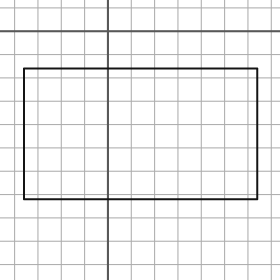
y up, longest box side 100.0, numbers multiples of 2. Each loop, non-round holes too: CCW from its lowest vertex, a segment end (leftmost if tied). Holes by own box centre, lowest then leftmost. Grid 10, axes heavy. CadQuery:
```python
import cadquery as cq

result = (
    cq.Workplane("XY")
    .moveTo(-36.0, -72.0)
    .lineTo(64.0, -72.0)
    .lineTo(64.0, -16.0)
    .lineTo(-36.0, -16.0)
    .close()
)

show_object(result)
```